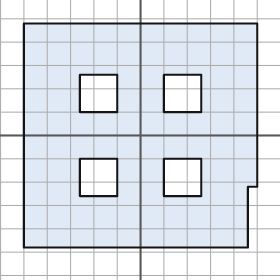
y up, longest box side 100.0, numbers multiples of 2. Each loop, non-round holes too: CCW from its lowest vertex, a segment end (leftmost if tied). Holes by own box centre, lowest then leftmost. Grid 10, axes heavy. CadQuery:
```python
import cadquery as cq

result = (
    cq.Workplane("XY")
    .moveTo(-50.0, -48.0)
    .lineTo(46.0, -48.0)
    .lineTo(46.0, -22.0)
    .lineTo(50.0, -22.0)
    .lineTo(50.0, 48.0)
    .lineTo(-50.0, 48.0)
    .close()
    .moveTo(-26.0, -26.0)
    .lineTo(-10.0, -26.0)
    .lineTo(-10.0, -10.0)
    .lineTo(-26.0, -10.0)
    .close()
    .moveTo(10.0, -26.0)
    .lineTo(26.0, -26.0)
    .lineTo(26.0, -10.0)
    .lineTo(10.0, -10.0)
    .close()
    .moveTo(-26.0, 10.0)
    .lineTo(-10.0, 10.0)
    .lineTo(-10.0, 26.0)
    .lineTo(-26.0, 26.0)
    .close()
    .moveTo(10.0, 10.0)
    .lineTo(26.0, 10.0)
    .lineTo(26.0, 26.0)
    .lineTo(10.0, 26.0)
    .close()
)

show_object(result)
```